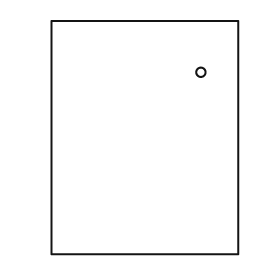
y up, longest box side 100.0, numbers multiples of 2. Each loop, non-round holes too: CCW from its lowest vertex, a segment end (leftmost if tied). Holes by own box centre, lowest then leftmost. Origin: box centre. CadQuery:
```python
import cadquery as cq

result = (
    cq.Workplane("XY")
    .moveTo(-40.0, -50.0)
    .lineTo(40.0, -50.0)
    .lineTo(40.0, 50.0)
    .lineTo(-40.0, 50.0)
    .close()
    .moveTo(24.0, 28.0)
    .circle(2.0)
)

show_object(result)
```